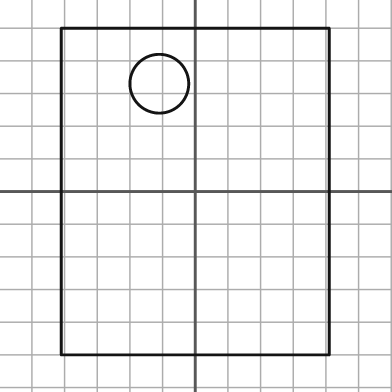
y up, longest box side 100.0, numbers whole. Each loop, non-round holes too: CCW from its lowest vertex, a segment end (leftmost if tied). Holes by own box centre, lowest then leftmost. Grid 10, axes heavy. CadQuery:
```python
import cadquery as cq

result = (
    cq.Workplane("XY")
    .moveTo(-41.0, -50.0)
    .lineTo(41.0, -50.0)
    .lineTo(41.0, 50.0)
    .lineTo(-41.0, 50.0)
    .close()
    .moveTo(-11.0, 33.0)
    .circle(9.0)
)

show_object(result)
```